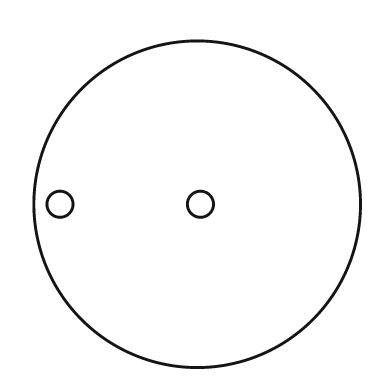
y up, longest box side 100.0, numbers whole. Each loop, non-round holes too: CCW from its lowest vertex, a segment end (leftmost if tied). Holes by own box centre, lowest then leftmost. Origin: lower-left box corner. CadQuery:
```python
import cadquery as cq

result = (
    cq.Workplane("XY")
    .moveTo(50.0, 50.0)
    .circle(50.0)
    .moveTo(8.0, 50.0)
    .circle(4.0)
    .moveTo(51.0, 50.0)
    .circle(4.0)
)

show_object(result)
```